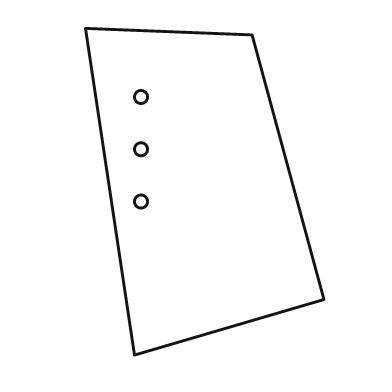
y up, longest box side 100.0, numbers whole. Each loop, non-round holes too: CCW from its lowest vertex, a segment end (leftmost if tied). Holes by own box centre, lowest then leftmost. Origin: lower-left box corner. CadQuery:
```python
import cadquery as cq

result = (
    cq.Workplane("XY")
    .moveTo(15.0, 0.0)
    .lineTo(73.0, 17.0)
    .lineTo(51.0, 98.0)
    .lineTo(0.0, 100.0)
    .close()
    .moveTo(17.0, 47.0)
    .circle(2.0)
    .moveTo(17.0, 63.0)
    .circle(2.0)
    .moveTo(17.0, 79.0)
    .circle(2.0)
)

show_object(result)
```